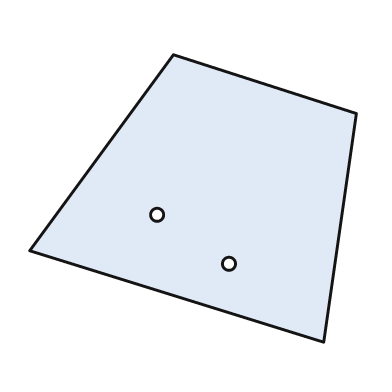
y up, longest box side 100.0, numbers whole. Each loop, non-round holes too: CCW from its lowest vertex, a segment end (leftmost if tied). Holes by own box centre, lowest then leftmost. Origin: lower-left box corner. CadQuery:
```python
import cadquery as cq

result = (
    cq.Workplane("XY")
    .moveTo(90.0, 0.0)
    .lineTo(100.0, 70.0)
    .lineTo(44.0, 88.0)
    .lineTo(0.0, 28.0)
    .close()
    .moveTo(61.0, 24.0)
    .circle(2.0)
    .moveTo(39.0, 39.0)
    .circle(2.0)
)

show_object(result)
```